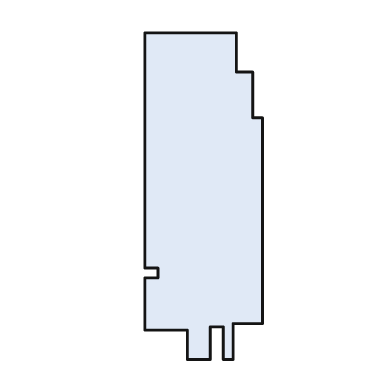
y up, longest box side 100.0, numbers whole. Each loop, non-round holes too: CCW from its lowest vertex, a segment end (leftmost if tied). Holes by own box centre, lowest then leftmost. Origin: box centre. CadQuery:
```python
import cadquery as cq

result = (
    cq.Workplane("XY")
    .moveTo(-5.0, -50.0)
    .lineTo(2.0, -50.0)
    .lineTo(2.0, -40.0)
    .lineTo(6.0, -40.0)
    .lineTo(6.0, -50.0)
    .lineTo(9.0, -50.0)
    .lineTo(9.0, -39.0)
    .lineTo(18.0, -39.0)
    .lineTo(18.0, 24.0)
    .lineTo(15.0, 24.0)
    .lineTo(15.0, 38.0)
    .lineTo(10.0, 38.0)
    .lineTo(10.0, 50.0)
    .lineTo(-18.0, 50.0)
    .lineTo(-18.0, -22.0)
    .lineTo(-14.0, -22.0)
    .lineTo(-14.0, -25.0)
    .lineTo(-18.0, -25.0)
    .lineTo(-18.0, -41.0)
    .lineTo(-5.0, -41.0)
    .close()
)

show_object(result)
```